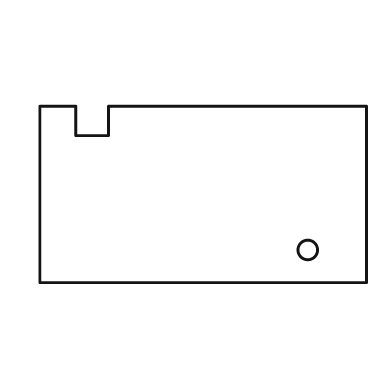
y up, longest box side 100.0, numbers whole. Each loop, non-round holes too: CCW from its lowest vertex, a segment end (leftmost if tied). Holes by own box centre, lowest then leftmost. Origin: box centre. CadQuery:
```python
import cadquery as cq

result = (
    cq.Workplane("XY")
    .moveTo(-50.0, -27.0)
    .lineTo(50.0, -27.0)
    .lineTo(50.0, 27.0)
    .lineTo(-29.0, 27.0)
    .lineTo(-29.0, 18.0)
    .lineTo(-39.0, 18.0)
    .lineTo(-39.0, 27.0)
    .lineTo(-50.0, 27.0)
    .close()
    .moveTo(32.0, -17.0)
    .circle(3.0)
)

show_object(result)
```